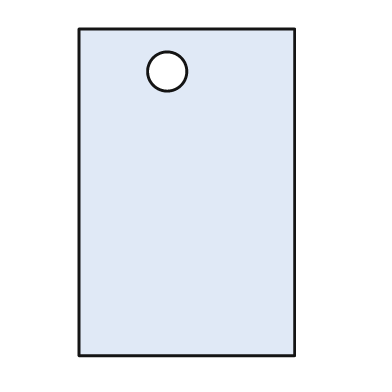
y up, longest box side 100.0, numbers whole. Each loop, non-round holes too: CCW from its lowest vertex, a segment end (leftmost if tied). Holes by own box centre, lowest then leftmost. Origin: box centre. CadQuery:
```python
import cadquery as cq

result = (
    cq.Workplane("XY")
    .moveTo(-33.0, -50.0)
    .lineTo(33.0, -50.0)
    .lineTo(33.0, 50.0)
    .lineTo(-33.0, 50.0)
    .close()
    .moveTo(-6.0, 37.0)
    .circle(6.0)
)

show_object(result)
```